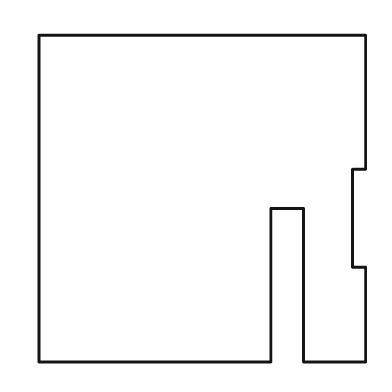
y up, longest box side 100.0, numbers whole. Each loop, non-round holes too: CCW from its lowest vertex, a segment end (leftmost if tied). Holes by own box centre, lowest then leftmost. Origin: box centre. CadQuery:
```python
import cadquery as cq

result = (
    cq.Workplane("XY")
    .moveTo(-50.0, -50.0)
    .lineTo(21.0, -50.0)
    .lineTo(21.0, -3.0)
    .lineTo(31.0, -3.0)
    .lineTo(31.0, -50.0)
    .lineTo(50.0, -50.0)
    .lineTo(50.0, -21.0)
    .lineTo(46.0, -21.0)
    .lineTo(46.0, 9.0)
    .lineTo(50.0, 9.0)
    .lineTo(50.0, 50.0)
    .lineTo(-50.0, 50.0)
    .close()
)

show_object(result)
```